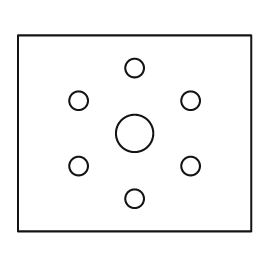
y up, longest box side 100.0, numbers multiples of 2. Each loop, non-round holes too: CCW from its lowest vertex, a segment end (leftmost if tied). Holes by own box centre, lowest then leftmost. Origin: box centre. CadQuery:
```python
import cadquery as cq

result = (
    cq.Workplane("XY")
    .moveTo(-50.0, -42.0)
    .lineTo(50.0, -42.0)
    .lineTo(50.0, 42.0)
    .lineTo(-50.0, 42.0)
    .close()
    .moveTo(0.0, -28.0)
    .circle(4.0)
    .moveTo(-24.0, -14.0)
    .circle(4.0)
    .moveTo(24.0, -14.0)
    .circle(4.0)
    .moveTo(0.0, 0.0)
    .circle(8.0)
    .moveTo(-24.0, 14.0)
    .circle(4.0)
    .moveTo(24.0, 14.0)
    .circle(4.0)
    .moveTo(0.0, 28.0)
    .circle(4.0)
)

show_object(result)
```